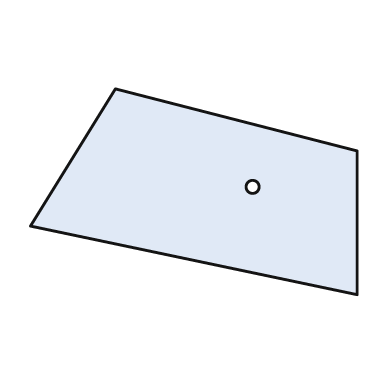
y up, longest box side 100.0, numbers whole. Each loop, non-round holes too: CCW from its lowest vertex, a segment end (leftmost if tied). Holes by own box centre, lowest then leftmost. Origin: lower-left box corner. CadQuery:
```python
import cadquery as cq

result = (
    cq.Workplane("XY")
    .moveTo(100.0, 0.0)
    .lineTo(100.0, 44.0)
    .lineTo(26.0, 63.0)
    .lineTo(0.0, 21.0)
    .close()
    .moveTo(68.0, 33.0)
    .circle(2.0)
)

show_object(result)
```